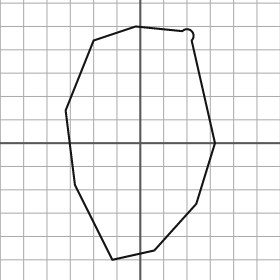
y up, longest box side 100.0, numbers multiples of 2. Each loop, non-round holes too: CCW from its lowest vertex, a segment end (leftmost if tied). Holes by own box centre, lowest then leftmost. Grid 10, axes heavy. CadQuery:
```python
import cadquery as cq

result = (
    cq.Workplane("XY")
    .moveTo(-12.0, -50.0)
    .lineTo(6.0, -46.0)
    .lineTo(24.0, -26.0)
    .lineTo(32.0, 0.0)
    .lineTo(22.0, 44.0)
    .threePointArc((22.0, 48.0), (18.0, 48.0))
    .lineTo(-2.0, 50.0)
    .lineTo(-20.0, 44.0)
    .lineTo(-32.0, 14.0)
    .lineTo(-28.0, -18.0)
    .close()
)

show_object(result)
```